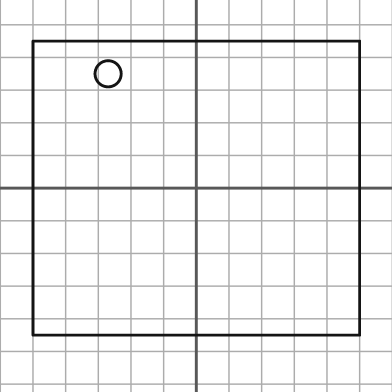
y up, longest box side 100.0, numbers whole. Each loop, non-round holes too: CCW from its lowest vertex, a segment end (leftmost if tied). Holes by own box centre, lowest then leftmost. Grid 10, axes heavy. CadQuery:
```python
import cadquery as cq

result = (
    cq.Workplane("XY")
    .moveTo(-50.0, -45.0)
    .lineTo(50.0, -45.0)
    .lineTo(50.0, 45.0)
    .lineTo(-50.0, 45.0)
    .close()
    .moveTo(-27.0, 35.0)
    .circle(4.0)
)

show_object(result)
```